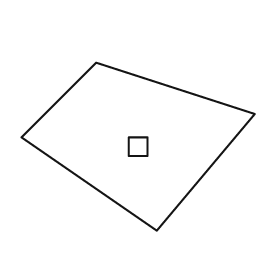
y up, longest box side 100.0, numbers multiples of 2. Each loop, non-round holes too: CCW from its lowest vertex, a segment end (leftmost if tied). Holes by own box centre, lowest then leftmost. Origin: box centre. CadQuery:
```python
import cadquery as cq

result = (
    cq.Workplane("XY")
    .moveTo(8.0, -36.0)
    .lineTo(50.0, 14.0)
    .lineTo(-18.0, 36.0)
    .lineTo(-50.0, 4.0)
    .close()
    .moveTo(-4.0, -4.0)
    .lineTo(4.0, -4.0)
    .lineTo(4.0, 4.0)
    .lineTo(-4.0, 4.0)
    .close()
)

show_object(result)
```